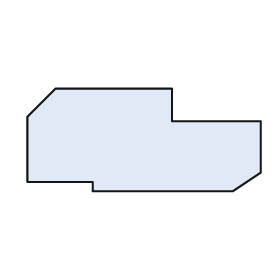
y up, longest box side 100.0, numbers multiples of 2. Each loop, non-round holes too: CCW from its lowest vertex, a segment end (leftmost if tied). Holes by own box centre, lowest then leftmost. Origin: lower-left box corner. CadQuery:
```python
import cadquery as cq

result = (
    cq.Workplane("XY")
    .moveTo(28.0, 0.0)
    .lineTo(88.0, 0.0)
    .lineTo(100.0, 8.0)
    .lineTo(100.0, 30.0)
    .lineTo(62.0, 30.0)
    .lineTo(62.0, 44.0)
    .lineTo(12.0, 44.0)
    .lineTo(0.0, 32.0)
    .lineTo(0.0, 4.0)
    .lineTo(28.0, 4.0)
    .close()
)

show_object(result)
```